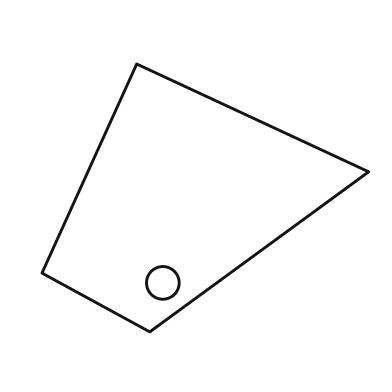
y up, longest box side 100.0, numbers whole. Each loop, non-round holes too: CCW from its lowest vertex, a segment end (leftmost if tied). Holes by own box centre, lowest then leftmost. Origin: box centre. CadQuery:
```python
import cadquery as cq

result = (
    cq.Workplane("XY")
    .moveTo(-17.0, -41.0)
    .lineTo(50.0, 8.0)
    .lineTo(-21.0, 41.0)
    .lineTo(-50.0, -23.0)
    .close()
    .moveTo(-13.0, -26.0)
    .circle(5.0)
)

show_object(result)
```